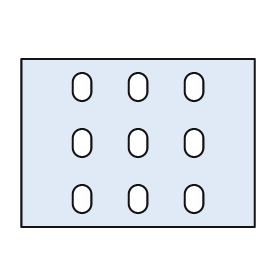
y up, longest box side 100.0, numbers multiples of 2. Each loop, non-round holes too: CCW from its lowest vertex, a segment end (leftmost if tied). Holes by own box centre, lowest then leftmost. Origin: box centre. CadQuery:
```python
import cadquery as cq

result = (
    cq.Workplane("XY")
    .moveTo(-50.0, -36.0)
    .lineTo(50.0, -36.0)
    .lineTo(50.0, 36.0)
    .lineTo(-50.0, 36.0)
    .close()
    .moveTo(-28.0, -26.0)
    .threePointArc((-24.0, -30.0), (-20.0, -26.0))
    .lineTo(-20.0, -22.0)
    .threePointArc((-24.0, -18.0), (-28.0, -22.0))
    .close()
    .moveTo(-4.0, -26.0)
    .threePointArc((0.0, -30.0), (4.0, -26.0))
    .lineTo(4.0, -22.0)
    .threePointArc((0.0, -18.0), (-4.0, -22.0))
    .close()
    .moveTo(20.0, -26.0)
    .threePointArc((24.0, -30.0), (28.0, -26.0))
    .lineTo(28.0, -22.0)
    .threePointArc((24.0, -18.0), (20.0, -22.0))
    .close()
    .moveTo(-28.0, -2.0)
    .threePointArc((-24.0, -6.0), (-20.0, -2.0))
    .lineTo(-20.0, 2.0)
    .threePointArc((-24.0, 6.0), (-28.0, 2.0))
    .close()
    .moveTo(-4.0, -2.0)
    .threePointArc((0.0, -6.0), (4.0, -2.0))
    .lineTo(4.0, 2.0)
    .threePointArc((0.0, 6.0), (-4.0, 2.0))
    .close()
    .moveTo(20.0, -2.0)
    .threePointArc((24.0, -6.0), (28.0, -2.0))
    .lineTo(28.0, 2.0)
    .threePointArc((24.0, 6.0), (20.0, 2.0))
    .close()
    .moveTo(-28.0, 22.0)
    .threePointArc((-24.0, 18.0), (-20.0, 22.0))
    .lineTo(-20.0, 26.0)
    .threePointArc((-24.0, 30.0), (-28.0, 26.0))
    .close()
    .moveTo(-4.0, 22.0)
    .threePointArc((0.0, 18.0), (4.0, 22.0))
    .lineTo(4.0, 26.0)
    .threePointArc((0.0, 30.0), (-4.0, 26.0))
    .close()
    .moveTo(20.0, 22.0)
    .threePointArc((24.0, 18.0), (28.0, 22.0))
    .lineTo(28.0, 26.0)
    .threePointArc((24.0, 30.0), (20.0, 26.0))
    .close()
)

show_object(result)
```